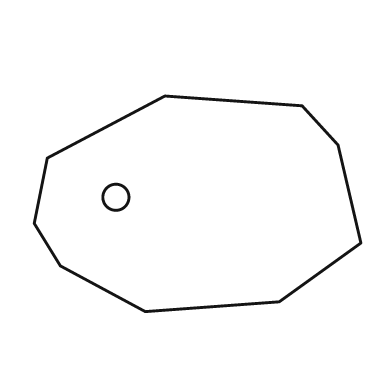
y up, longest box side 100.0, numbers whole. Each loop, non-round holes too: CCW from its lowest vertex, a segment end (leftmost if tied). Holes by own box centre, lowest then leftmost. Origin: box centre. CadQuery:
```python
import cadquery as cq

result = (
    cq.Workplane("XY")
    .moveTo(-16.0, -33.0)
    .lineTo(25.0, -30.0)
    .lineTo(50.0, -12.0)
    .lineTo(43.0, 18.0)
    .lineTo(32.0, 30.0)
    .lineTo(-10.0, 33.0)
    .lineTo(-46.0, 14.0)
    .lineTo(-50.0, -6.0)
    .lineTo(-42.0, -19.0)
    .close()
    .moveTo(-25.0, 2.0)
    .circle(4.0)
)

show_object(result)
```